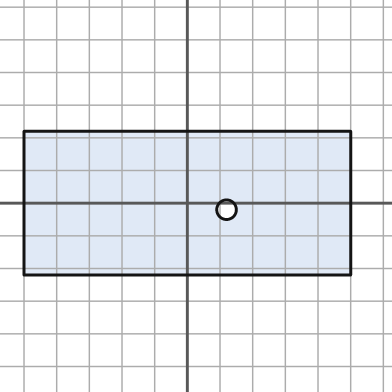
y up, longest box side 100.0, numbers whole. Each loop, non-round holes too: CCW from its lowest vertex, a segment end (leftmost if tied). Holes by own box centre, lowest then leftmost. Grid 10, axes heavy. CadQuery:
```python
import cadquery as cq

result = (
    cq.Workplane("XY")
    .moveTo(-50.0, -22.0)
    .lineTo(50.0, -22.0)
    .lineTo(50.0, 22.0)
    .lineTo(-50.0, 22.0)
    .close()
    .moveTo(12.0, -2.0)
    .circle(3.0)
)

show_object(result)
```